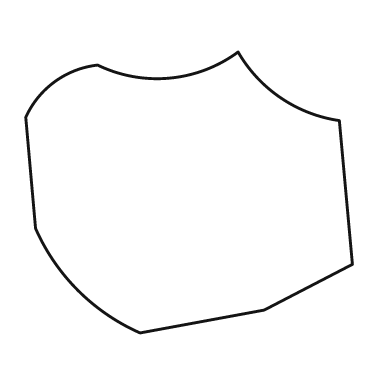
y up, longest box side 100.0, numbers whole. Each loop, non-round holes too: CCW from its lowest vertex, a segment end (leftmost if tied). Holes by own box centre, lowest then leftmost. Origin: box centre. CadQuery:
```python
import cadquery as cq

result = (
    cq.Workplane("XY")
    .moveTo(-15.0, -43.0)
    .lineTo(23.0, -36.0)
    .lineTo(50.0, -22.0)
    .lineTo(46.0, 22.0)
    .threePointArc((28.0, 29.0), (15.0, 43.0))
    .threePointArc((-6.0, 35.0), (-28.0, 39.0))
    .threePointArc((-41.0, 34.0), (-50.0, 23.0))
    .lineTo(-47.0, -11.0)
    .threePointArc((-34.0, -30.0), (-15.0, -43.0))
    .close()
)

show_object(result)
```